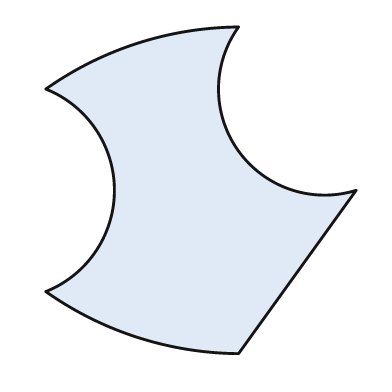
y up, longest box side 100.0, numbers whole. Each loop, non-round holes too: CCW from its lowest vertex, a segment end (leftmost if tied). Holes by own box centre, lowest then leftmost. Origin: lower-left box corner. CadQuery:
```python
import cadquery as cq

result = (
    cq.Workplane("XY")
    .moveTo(59.0, 0.0)
    .lineTo(95.0, 50.0)
    .threePointArc((59.0, 62.0), (59.0, 100.0))
    .threePointArc((28.0, 95.0), (0.0, 81.0))
    .threePointArc((21.0, 50.0), (0.0, 19.0))
    .threePointArc((28.0, 5.0), (59.0, 0.0))
    .close()
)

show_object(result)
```